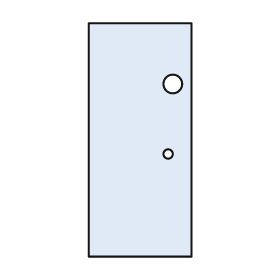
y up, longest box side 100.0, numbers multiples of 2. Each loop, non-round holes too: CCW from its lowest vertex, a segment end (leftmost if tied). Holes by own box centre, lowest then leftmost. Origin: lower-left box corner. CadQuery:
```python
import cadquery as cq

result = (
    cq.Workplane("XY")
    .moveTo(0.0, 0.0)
    .lineTo(44.0, 0.0)
    .lineTo(44.0, 100.0)
    .lineTo(0.0, 100.0)
    .close()
    .moveTo(34.0, 44.0)
    .circle(2.0)
    .moveTo(36.0, 74.0)
    .circle(4.0)
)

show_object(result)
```